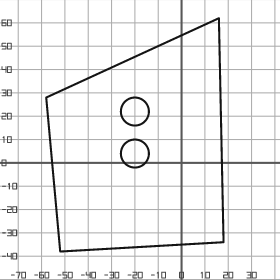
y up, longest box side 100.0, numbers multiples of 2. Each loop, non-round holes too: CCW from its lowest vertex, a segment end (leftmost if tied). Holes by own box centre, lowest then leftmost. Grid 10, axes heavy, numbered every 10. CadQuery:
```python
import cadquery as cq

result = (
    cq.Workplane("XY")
    .moveTo(-52.0, -38.0)
    .lineTo(18.0, -34.0)
    .lineTo(16.0, 62.0)
    .lineTo(-58.0, 28.0)
    .close()
    .moveTo(-20.0, 4.0)
    .circle(6.0)
    .moveTo(-20.0, 22.0)
    .circle(6.0)
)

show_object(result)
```